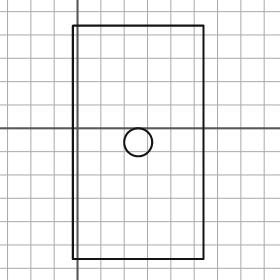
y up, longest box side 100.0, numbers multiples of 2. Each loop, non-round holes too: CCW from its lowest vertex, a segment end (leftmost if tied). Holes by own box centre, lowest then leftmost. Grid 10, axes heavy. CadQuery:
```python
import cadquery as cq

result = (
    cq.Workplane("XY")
    .moveTo(-2.0, -56.0)
    .lineTo(54.0, -56.0)
    .lineTo(54.0, 44.0)
    .lineTo(-2.0, 44.0)
    .close()
    .moveTo(26.0, -6.0)
    .circle(6.0)
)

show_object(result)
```